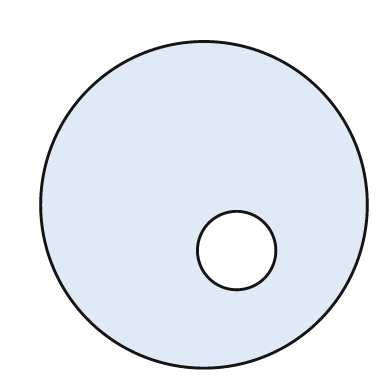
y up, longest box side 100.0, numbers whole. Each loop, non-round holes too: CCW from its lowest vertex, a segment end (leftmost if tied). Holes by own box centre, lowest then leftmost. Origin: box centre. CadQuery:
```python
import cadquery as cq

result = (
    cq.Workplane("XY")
    .moveTo(0.0, 0.0)
    .circle(50.0)
    .moveTo(10.0, -14.0)
    .circle(12.0)
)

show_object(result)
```